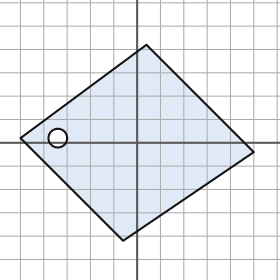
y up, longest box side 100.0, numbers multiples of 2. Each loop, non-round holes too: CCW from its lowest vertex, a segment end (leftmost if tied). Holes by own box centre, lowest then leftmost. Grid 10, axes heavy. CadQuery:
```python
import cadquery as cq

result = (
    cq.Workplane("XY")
    .moveTo(-6.0, -42.0)
    .lineTo(50.0, -4.0)
    .lineTo(4.0, 42.0)
    .lineTo(-50.0, 2.0)
    .close()
    .moveTo(-34.0, 2.0)
    .circle(4.0)
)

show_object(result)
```